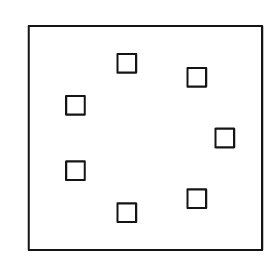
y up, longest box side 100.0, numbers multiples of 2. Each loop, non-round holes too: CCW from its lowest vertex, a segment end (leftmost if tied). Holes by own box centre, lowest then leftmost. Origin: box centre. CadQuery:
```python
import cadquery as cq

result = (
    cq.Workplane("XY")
    .moveTo(-50.0, -48.0)
    .lineTo(50.0, -48.0)
    .lineTo(50.0, 48.0)
    .lineTo(-50.0, 48.0)
    .close()
    .moveTo(-12.0, -36.0)
    .lineTo(-4.0, -36.0)
    .lineTo(-4.0, -28.0)
    .lineTo(-12.0, -28.0)
    .close()
    .moveTo(18.0, -30.0)
    .lineTo(26.0, -30.0)
    .lineTo(26.0, -22.0)
    .lineTo(18.0, -22.0)
    .close()
    .moveTo(-34.0, -18.0)
    .lineTo(-26.0, -18.0)
    .lineTo(-26.0, -10.0)
    .lineTo(-34.0, -10.0)
    .close()
    .moveTo(30.0, -4.0)
    .lineTo(38.0, -4.0)
    .lineTo(38.0, 4.0)
    .lineTo(30.0, 4.0)
    .close()
    .moveTo(-34.0, 10.0)
    .lineTo(-26.0, 10.0)
    .lineTo(-26.0, 18.0)
    .lineTo(-34.0, 18.0)
    .close()
    .moveTo(18.0, 22.0)
    .lineTo(26.0, 22.0)
    .lineTo(26.0, 30.0)
    .lineTo(18.0, 30.0)
    .close()
    .moveTo(-12.0, 28.0)
    .lineTo(-4.0, 28.0)
    .lineTo(-4.0, 36.0)
    .lineTo(-12.0, 36.0)
    .close()
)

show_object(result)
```